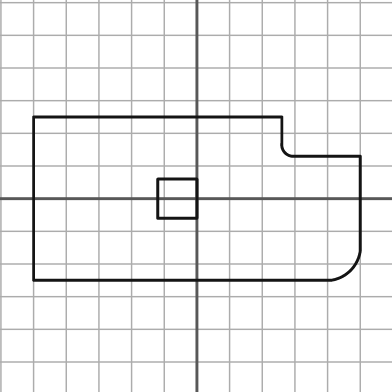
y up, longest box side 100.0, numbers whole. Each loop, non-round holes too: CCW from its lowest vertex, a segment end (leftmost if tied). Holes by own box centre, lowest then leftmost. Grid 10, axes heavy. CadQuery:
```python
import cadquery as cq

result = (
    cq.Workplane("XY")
    .moveTo(-50.0, -25.0)
    .lineTo(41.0, -25.0)
    .threePointArc((47.0, -22.0), (50.0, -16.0))
    .lineTo(50.0, 13.0)
    .lineTo(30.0, 13.0)
    .threePointArc((27.0, 14.0), (26.0, 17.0))
    .lineTo(26.0, 25.0)
    .lineTo(-50.0, 25.0)
    .close()
    .moveTo(-12.0, -6.0)
    .lineTo(0.0, -6.0)
    .lineTo(0.0, 6.0)
    .lineTo(-12.0, 6.0)
    .close()
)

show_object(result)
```